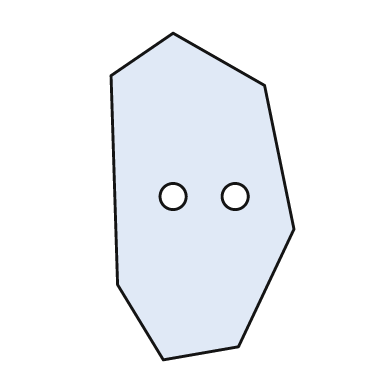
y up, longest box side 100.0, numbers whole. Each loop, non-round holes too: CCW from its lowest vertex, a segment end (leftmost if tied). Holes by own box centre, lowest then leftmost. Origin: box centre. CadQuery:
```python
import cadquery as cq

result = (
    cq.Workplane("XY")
    .moveTo(-12.0, -50.0)
    .lineTo(11.0, -46.0)
    .lineTo(28.0, -10.0)
    .lineTo(19.0, 34.0)
    .lineTo(-9.0, 50.0)
    .lineTo(-28.0, 37.0)
    .lineTo(-26.0, -27.0)
    .close()
    .moveTo(-9.0, 0.0)
    .circle(4.0)
    .moveTo(10.0, 0.0)
    .circle(4.0)
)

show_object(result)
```